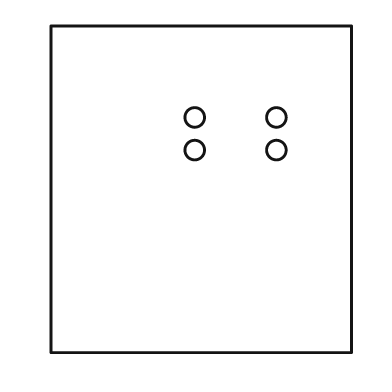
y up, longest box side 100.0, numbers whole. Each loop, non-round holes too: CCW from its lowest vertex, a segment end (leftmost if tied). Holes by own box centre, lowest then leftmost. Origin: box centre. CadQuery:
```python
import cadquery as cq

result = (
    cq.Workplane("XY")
    .moveTo(-46.0, -50.0)
    .lineTo(46.0, -50.0)
    .lineTo(46.0, 50.0)
    .lineTo(-46.0, 50.0)
    .close()
    .moveTo(-2.0, 12.0)
    .circle(3.0)
    .moveTo(23.0, 12.0)
    .circle(3.0)
    .moveTo(-2.0, 22.0)
    .circle(3.0)
    .moveTo(23.0, 22.0)
    .circle(3.0)
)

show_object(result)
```